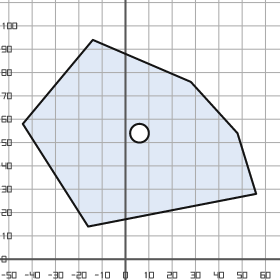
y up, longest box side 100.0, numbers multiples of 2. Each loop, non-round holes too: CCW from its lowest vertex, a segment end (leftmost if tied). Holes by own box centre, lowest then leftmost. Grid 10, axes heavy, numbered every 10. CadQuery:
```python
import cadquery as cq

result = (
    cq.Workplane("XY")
    .moveTo(-16.0, 14.0)
    .lineTo(56.0, 28.0)
    .lineTo(48.0, 54.0)
    .lineTo(28.0, 76.0)
    .lineTo(-14.0, 94.0)
    .lineTo(-44.0, 58.0)
    .close()
    .moveTo(6.0, 54.0)
    .circle(4.0)
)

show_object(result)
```